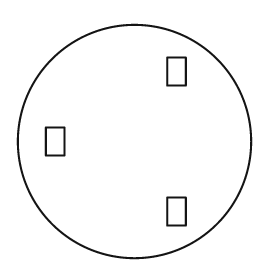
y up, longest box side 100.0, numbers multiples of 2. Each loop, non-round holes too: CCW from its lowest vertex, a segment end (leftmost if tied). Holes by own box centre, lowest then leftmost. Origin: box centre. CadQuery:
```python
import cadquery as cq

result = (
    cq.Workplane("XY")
    .moveTo(0.0, 0.0)
    .circle(50.0)
    .moveTo(14.0, -36.0)
    .lineTo(22.0, -36.0)
    .lineTo(22.0, -24.0)
    .lineTo(14.0, -24.0)
    .close()
    .moveTo(-38.0, -6.0)
    .lineTo(-30.0, -6.0)
    .lineTo(-30.0, 6.0)
    .lineTo(-38.0, 6.0)
    .close()
    .moveTo(14.0, 24.0)
    .lineTo(22.0, 24.0)
    .lineTo(22.0, 36.0)
    .lineTo(14.0, 36.0)
    .close()
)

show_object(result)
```